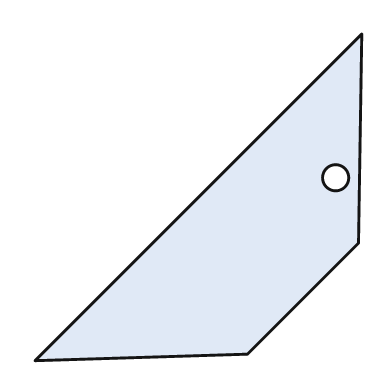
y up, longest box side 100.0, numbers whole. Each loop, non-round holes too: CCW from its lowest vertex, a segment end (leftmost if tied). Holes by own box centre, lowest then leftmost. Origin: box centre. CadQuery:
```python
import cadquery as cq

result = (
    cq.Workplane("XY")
    .moveTo(-50.0, -50.0)
    .lineTo(15.0, -48.0)
    .lineTo(49.0, -14.0)
    .lineTo(50.0, 50.0)
    .close()
    .moveTo(42.0, 6.0)
    .circle(4.0)
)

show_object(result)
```